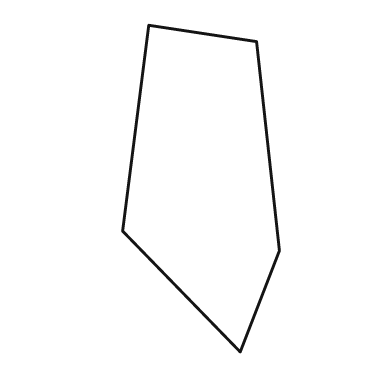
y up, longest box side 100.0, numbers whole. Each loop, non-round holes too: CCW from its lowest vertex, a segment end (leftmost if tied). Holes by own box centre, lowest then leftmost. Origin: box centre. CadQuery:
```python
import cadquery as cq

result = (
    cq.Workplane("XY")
    .moveTo(12.0, -50.0)
    .lineTo(24.0, -19.0)
    .lineTo(17.0, 45.0)
    .lineTo(-16.0, 50.0)
    .lineTo(-24.0, -13.0)
    .close()
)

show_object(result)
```